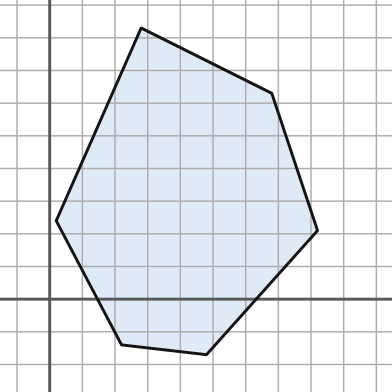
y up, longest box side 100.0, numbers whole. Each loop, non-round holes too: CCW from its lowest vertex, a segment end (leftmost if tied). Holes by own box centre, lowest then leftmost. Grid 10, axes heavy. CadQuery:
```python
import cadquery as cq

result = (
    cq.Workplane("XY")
    .moveTo(48.0, -17.0)
    .lineTo(82.0, 21.0)
    .lineTo(68.0, 63.0)
    .lineTo(28.0, 83.0)
    .lineTo(2.0, 24.0)
    .lineTo(22.0, -14.0)
    .close()
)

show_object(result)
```